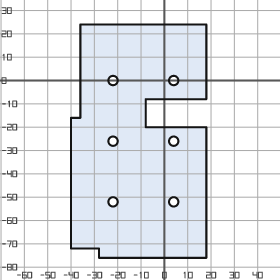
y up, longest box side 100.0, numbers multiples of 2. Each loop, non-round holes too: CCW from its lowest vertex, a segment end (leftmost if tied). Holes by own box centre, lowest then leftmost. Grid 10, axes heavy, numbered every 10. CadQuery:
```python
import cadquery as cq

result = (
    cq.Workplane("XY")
    .moveTo(-28.0, -76.0)
    .lineTo(18.0, -76.0)
    .lineTo(18.0, -20.0)
    .lineTo(-8.0, -20.0)
    .lineTo(-8.0, -8.0)
    .lineTo(18.0, -8.0)
    .lineTo(18.0, 24.0)
    .lineTo(-36.0, 24.0)
    .lineTo(-36.0, -16.0)
    .lineTo(-40.0, -16.0)
    .lineTo(-40.0, -72.0)
    .lineTo(-28.0, -72.0)
    .close()
    .moveTo(-22.0, -52.0)
    .circle(2.0)
    .moveTo(4.0, -52.0)
    .circle(2.0)
    .moveTo(-22.0, -26.0)
    .circle(2.0)
    .moveTo(4.0, -26.0)
    .circle(2.0)
    .moveTo(-22.0, 0.0)
    .circle(2.0)
    .moveTo(4.0, 0.0)
    .circle(2.0)
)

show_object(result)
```